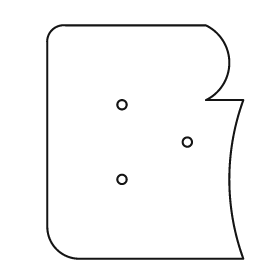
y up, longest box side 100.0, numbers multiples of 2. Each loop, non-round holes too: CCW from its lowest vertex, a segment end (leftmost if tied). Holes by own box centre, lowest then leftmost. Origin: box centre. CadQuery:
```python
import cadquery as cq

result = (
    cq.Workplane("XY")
    .moveTo(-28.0, -50.0)
    .lineTo(42.0, -50.0)
    .threePointArc((36.0, -16.0), (42.0, 18.0))
    .lineTo(26.0, 18.0)
    .threePointArc((36.0, 34.0), (26.0, 50.0))
    .lineTo(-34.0, 50.0)
    .threePointArc((-40.0, 48.0), (-42.0, 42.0))
    .lineTo(-42.0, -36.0)
    .threePointArc((-38.0, -46.0), (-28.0, -50.0))
    .close()
    .moveTo(-10.0, -16.0)
    .circle(2.0)
    .moveTo(18.0, 0.0)
    .circle(2.0)
    .moveTo(-10.0, 16.0)
    .circle(2.0)
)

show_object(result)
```